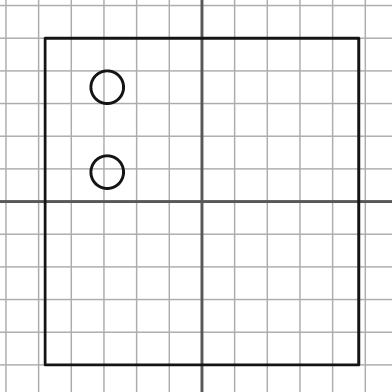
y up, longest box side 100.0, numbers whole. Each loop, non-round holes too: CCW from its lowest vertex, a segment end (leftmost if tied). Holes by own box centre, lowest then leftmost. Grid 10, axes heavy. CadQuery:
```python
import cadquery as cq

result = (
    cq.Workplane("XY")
    .moveTo(-48.0, -50.0)
    .lineTo(48.0, -50.0)
    .lineTo(48.0, 50.0)
    .lineTo(-48.0, 50.0)
    .close()
    .moveTo(-29.0, 9.0)
    .circle(5.0)
    .moveTo(-29.0, 35.0)
    .circle(5.0)
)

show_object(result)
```